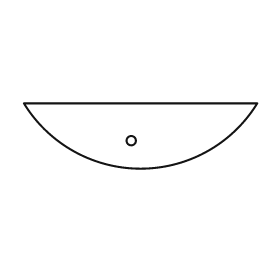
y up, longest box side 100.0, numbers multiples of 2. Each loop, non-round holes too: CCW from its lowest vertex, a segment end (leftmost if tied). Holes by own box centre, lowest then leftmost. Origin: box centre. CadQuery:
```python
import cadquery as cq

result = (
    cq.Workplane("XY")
    .moveTo(-50.0, 14.0)
    .threePointArc((0.0, -14.0), (50.0, 14.0))
    .close()
    .moveTo(-4.0, -2.0)
    .circle(2.0)
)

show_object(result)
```